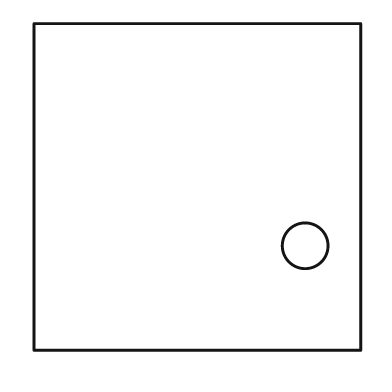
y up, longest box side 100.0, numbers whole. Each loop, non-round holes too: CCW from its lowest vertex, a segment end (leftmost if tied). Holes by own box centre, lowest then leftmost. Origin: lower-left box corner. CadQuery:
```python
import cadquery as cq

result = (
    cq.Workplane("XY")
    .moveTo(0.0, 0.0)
    .lineTo(100.0, 0.0)
    .lineTo(100.0, 100.0)
    .lineTo(0.0, 100.0)
    .close()
    .moveTo(83.0, 32.0)
    .circle(7.0)
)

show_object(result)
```